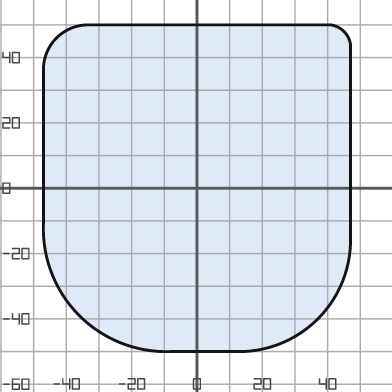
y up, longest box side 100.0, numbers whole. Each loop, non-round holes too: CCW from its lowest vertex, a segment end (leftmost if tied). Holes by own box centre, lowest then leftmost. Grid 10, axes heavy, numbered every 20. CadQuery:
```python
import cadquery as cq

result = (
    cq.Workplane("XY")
    .moveTo(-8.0, -50.0)
    .lineTo(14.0, -50.0)
    .threePointArc((37.0, -40.0), (47.0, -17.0))
    .lineTo(47.0, 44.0)
    .threePointArc((45.0, 48.0), (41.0, 50.0))
    .lineTo(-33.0, 50.0)
    .threePointArc((-43.0, 46.0), (-47.0, 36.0))
    .lineTo(-47.0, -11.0)
    .threePointArc((-36.0, -39.0), (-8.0, -50.0))
    .close()
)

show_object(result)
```